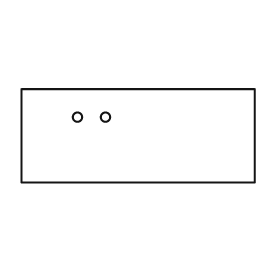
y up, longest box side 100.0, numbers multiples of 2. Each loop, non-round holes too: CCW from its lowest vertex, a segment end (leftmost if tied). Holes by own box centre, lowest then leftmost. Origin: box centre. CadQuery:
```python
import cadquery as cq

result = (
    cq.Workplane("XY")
    .moveTo(-50.0, -20.0)
    .lineTo(50.0, -20.0)
    .lineTo(50.0, 20.0)
    .lineTo(-50.0, 20.0)
    .close()
    .moveTo(-26.0, 8.0)
    .circle(2.0)
    .moveTo(-14.0, 8.0)
    .circle(2.0)
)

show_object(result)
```